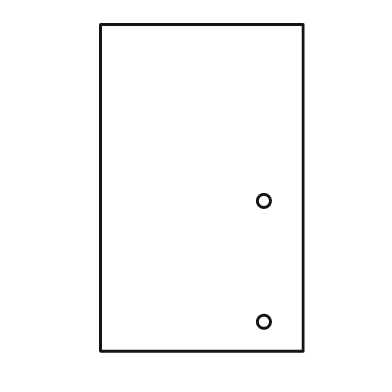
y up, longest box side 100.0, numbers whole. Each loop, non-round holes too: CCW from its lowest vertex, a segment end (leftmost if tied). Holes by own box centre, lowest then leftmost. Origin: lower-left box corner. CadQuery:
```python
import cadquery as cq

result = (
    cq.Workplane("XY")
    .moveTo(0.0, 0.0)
    .lineTo(62.0, 0.0)
    .lineTo(62.0, 100.0)
    .lineTo(0.0, 100.0)
    .close()
    .moveTo(50.0, 9.0)
    .circle(2.0)
    .moveTo(50.0, 46.0)
    .circle(2.0)
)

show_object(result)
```